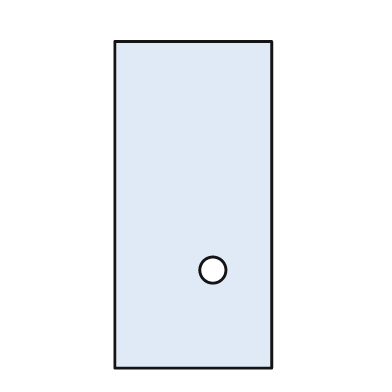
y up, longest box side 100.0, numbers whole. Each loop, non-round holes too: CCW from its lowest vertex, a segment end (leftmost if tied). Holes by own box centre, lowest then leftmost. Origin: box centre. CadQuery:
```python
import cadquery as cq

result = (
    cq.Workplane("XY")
    .moveTo(-24.0, -50.0)
    .lineTo(24.0, -50.0)
    .lineTo(24.0, 50.0)
    .lineTo(-24.0, 50.0)
    .close()
    .moveTo(6.0, -20.0)
    .circle(4.0)
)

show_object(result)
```